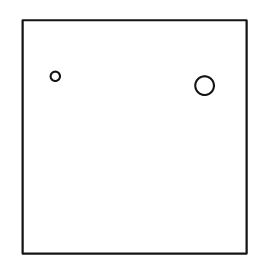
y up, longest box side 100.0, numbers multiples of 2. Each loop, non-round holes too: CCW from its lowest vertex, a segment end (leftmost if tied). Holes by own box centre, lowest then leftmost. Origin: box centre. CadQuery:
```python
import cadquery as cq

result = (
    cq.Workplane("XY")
    .moveTo(-48.0, -50.0)
    .lineTo(48.0, -50.0)
    .lineTo(48.0, 50.0)
    .lineTo(-48.0, 50.0)
    .close()
    .moveTo(30.0, 22.0)
    .circle(4.0)
    .moveTo(-34.0, 26.0)
    .circle(2.0)
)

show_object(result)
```